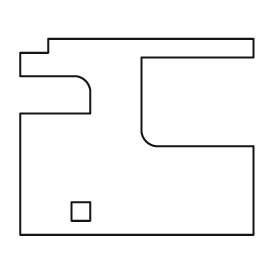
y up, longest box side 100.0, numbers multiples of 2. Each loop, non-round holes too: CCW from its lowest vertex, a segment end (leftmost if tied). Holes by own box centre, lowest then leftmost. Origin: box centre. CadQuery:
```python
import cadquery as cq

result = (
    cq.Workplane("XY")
    .moveTo(-50.0, -42.0)
    .lineTo(50.0, -42.0)
    .lineTo(50.0, -4.0)
    .lineTo(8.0, -4.0)
    .threePointArc((4.0, -2.0), (2.0, 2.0))
    .lineTo(2.0, 34.0)
    .lineTo(50.0, 34.0)
    .lineTo(50.0, 42.0)
    .lineTo(-38.0, 42.0)
    .lineTo(-38.0, 36.0)
    .lineTo(-50.0, 36.0)
    .lineTo(-50.0, 26.0)
    .lineTo(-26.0, 26.0)
    .threePointArc((-22.0, 24.0), (-20.0, 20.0))
    .lineTo(-20.0, 10.0)
    .lineTo(-50.0, 10.0)
    .close()
    .moveTo(-28.0, -36.0)
    .lineTo(-20.0, -36.0)
    .lineTo(-20.0, -28.0)
    .lineTo(-28.0, -28.0)
    .close()
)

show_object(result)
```